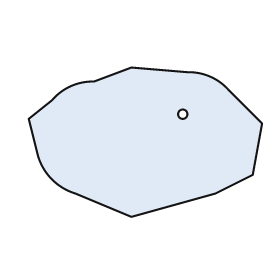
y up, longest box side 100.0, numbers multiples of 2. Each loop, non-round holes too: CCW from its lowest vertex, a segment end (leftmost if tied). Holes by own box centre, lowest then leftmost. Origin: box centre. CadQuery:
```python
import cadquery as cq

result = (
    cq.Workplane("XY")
    .moveTo(-6.0, -32.0)
    .lineTo(30.0, -22.0)
    .lineTo(46.0, -14.0)
    .lineTo(50.0, 8.0)
    .lineTo(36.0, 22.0)
    .threePointArc((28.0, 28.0), (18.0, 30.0))
    .lineTo(-6.0, 32.0)
    .lineTo(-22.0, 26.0)
    .threePointArc((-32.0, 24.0), (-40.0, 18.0))
    .lineTo(-50.0, 10.0)
    .lineTo(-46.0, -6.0)
    .threePointArc((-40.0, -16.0), (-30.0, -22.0))
    .close()
    .moveTo(16.0, 12.0)
    .circle(2.0)
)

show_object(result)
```